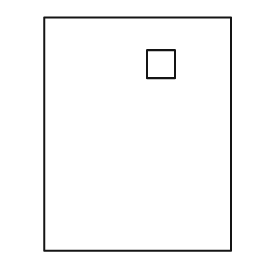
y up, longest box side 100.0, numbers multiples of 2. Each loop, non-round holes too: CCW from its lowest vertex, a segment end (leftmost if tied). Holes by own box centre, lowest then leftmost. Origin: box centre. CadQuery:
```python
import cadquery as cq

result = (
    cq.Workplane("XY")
    .moveTo(-40.0, -50.0)
    .lineTo(40.0, -50.0)
    .lineTo(40.0, 50.0)
    .lineTo(-40.0, 50.0)
    .close()
    .moveTo(4.0, 24.0)
    .lineTo(16.0, 24.0)
    .lineTo(16.0, 36.0)
    .lineTo(4.0, 36.0)
    .close()
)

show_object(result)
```